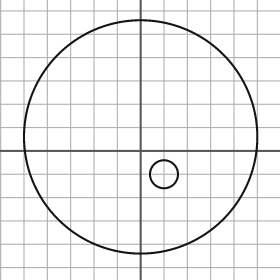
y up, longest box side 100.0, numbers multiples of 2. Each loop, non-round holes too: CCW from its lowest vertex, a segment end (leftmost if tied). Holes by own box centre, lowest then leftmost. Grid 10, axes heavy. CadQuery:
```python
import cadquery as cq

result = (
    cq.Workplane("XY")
    .moveTo(0.0, 6.0)
    .circle(50.0)
    .moveTo(10.0, -10.0)
    .circle(6.0)
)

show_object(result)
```